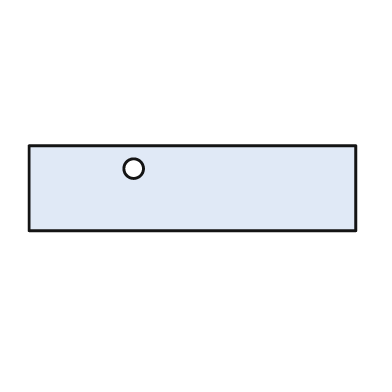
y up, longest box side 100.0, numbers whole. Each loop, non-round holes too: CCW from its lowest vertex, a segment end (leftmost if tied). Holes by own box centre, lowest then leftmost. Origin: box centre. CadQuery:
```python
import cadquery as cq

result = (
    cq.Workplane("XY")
    .moveTo(-50.0, -13.0)
    .lineTo(50.0, -13.0)
    .lineTo(50.0, 13.0)
    .lineTo(-50.0, 13.0)
    .close()
    .moveTo(-18.0, 6.0)
    .circle(3.0)
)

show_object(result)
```